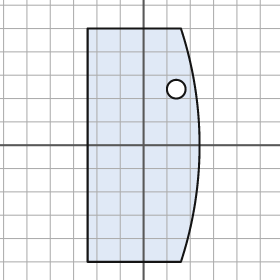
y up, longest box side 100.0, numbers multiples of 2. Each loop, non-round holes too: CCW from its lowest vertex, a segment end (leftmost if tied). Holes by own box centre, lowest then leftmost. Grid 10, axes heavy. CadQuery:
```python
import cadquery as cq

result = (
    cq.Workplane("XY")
    .moveTo(-24.0, -50.0)
    .lineTo(16.0, -50.0)
    .threePointArc((24.0, 0.0), (16.0, 50.0))
    .lineTo(-24.0, 50.0)
    .close()
    .moveTo(14.0, 24.0)
    .circle(4.0)
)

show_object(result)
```